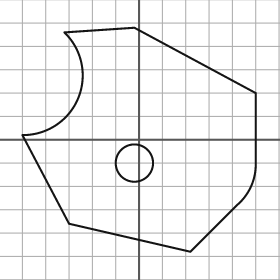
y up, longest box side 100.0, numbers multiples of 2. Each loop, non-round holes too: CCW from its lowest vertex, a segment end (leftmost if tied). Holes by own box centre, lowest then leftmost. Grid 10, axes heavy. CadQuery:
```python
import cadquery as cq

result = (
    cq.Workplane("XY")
    .moveTo(22.0, -48.0)
    .lineTo(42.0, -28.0)
    .threePointArc((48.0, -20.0), (50.0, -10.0))
    .lineTo(50.0, 20.0)
    .lineTo(-2.0, 48.0)
    .lineTo(-32.0, 46.0)
    .threePointArc((-26.0, 18.0), (-50.0, 2.0))
    .lineTo(-30.0, -36.0)
    .close()
    .moveTo(-2.0, -10.0)
    .circle(8.0)
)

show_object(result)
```